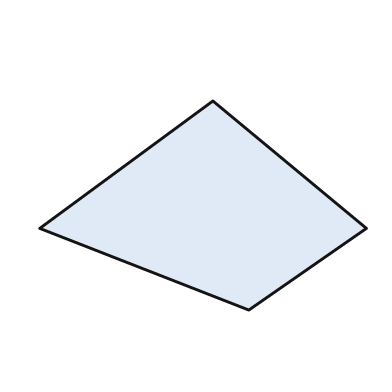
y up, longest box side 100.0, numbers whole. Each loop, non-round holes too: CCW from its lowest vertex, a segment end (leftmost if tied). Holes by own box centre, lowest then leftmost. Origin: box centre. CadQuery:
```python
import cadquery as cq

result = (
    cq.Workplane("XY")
    .moveTo(14.0, -32.0)
    .lineTo(50.0, -7.0)
    .lineTo(3.0, 32.0)
    .lineTo(-50.0, -7.0)
    .close()
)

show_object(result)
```